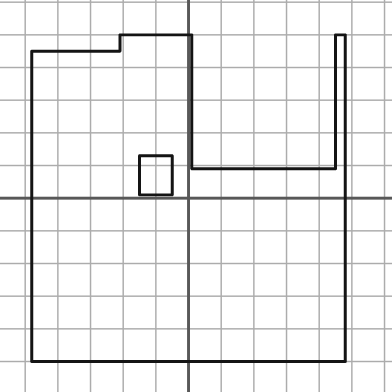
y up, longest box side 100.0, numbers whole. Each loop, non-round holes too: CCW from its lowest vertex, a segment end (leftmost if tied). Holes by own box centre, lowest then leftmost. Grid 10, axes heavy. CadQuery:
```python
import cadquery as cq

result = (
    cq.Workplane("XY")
    .moveTo(-48.0, -50.0)
    .lineTo(48.0, -50.0)
    .lineTo(48.0, 50.0)
    .lineTo(45.0, 50.0)
    .lineTo(45.0, 9.0)
    .lineTo(1.0, 9.0)
    .lineTo(1.0, 50.0)
    .lineTo(-21.0, 50.0)
    .lineTo(-21.0, 45.0)
    .lineTo(-48.0, 45.0)
    .close()
    .moveTo(-15.0, 1.0)
    .lineTo(-5.0, 1.0)
    .lineTo(-5.0, 13.0)
    .lineTo(-15.0, 13.0)
    .close()
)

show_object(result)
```